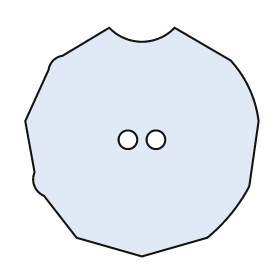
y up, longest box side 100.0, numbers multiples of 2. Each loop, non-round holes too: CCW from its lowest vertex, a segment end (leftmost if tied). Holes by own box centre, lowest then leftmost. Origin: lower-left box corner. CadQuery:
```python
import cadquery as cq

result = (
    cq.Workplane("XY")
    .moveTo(50.0, 0.0)
    .lineTo(78.0, 8.0)
    .threePointArc((88.0, 18.0), (96.0, 30.0))
    .lineTo(100.0, 58.0)
    .threePointArc((96.0, 72.0), (88.0, 84.0))
    .lineTo(64.0, 98.0)
    .threePointArc((50.0, 92.0), (36.0, 98.0))
    .lineTo(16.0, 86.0)
    .threePointArc((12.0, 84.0), (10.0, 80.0))
    .lineTo(0.0, 58.0)
    .lineTo(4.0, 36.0)
    .threePointArc((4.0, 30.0), (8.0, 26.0))
    .lineTo(22.0, 8.0)
    .close()
    .moveTo(44.0, 50.0)
    .circle(4.0)
    .moveTo(56.0, 50.0)
    .circle(4.0)
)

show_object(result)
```